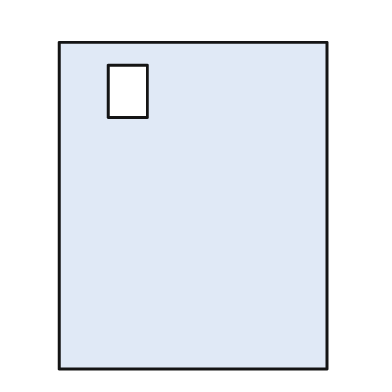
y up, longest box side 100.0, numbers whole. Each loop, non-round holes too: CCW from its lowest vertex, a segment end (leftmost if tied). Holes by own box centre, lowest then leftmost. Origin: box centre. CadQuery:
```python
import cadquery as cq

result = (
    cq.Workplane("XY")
    .moveTo(-41.0, -50.0)
    .lineTo(41.0, -50.0)
    .lineTo(41.0, 50.0)
    .lineTo(-41.0, 50.0)
    .close()
    .moveTo(-26.0, 27.0)
    .lineTo(-14.0, 27.0)
    .lineTo(-14.0, 43.0)
    .lineTo(-26.0, 43.0)
    .close()
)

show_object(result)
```